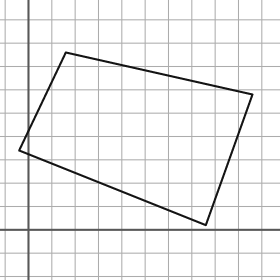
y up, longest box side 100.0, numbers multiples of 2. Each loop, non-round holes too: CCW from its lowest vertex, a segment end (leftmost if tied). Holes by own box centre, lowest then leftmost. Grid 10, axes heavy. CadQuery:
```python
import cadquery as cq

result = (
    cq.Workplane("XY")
    .moveTo(76.0, 2.0)
    .lineTo(96.0, 58.0)
    .lineTo(16.0, 76.0)
    .lineTo(-4.0, 34.0)
    .close()
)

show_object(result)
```